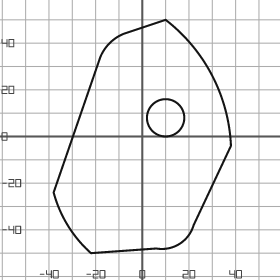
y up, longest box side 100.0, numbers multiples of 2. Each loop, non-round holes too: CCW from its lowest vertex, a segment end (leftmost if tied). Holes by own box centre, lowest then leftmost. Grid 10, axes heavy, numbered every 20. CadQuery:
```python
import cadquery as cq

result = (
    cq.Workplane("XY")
    .moveTo(-22.0, -50.0)
    .lineTo(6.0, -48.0)
    .threePointArc((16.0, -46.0), (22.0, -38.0))
    .lineTo(38.0, -4.0)
    .threePointArc((30.0, 26.0), (10.0, 50.0))
    .lineTo(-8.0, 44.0)
    .threePointArc((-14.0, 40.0), (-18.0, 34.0))
    .lineTo(-38.0, -24.0)
    .threePointArc((-32.0, -38.0), (-22.0, -50.0))
    .close()
    .moveTo(10.0, 8.0)
    .circle(8.0)
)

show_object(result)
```